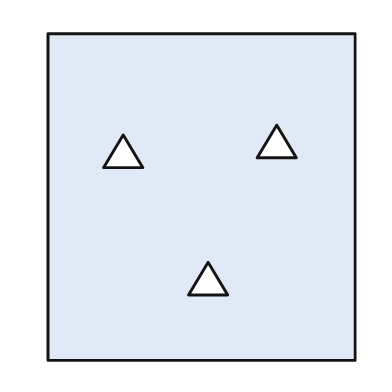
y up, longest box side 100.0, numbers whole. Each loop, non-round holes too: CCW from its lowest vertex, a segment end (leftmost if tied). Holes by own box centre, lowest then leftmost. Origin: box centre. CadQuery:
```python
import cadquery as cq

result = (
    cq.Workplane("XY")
    .moveTo(-47.0, -50.0)
    .lineTo(47.0, -50.0)
    .lineTo(47.0, 50.0)
    .lineTo(-47.0, 50.0)
    .close()
    .moveTo(-4.0, -30.0)
    .lineTo(8.0, -30.0)
    .lineTo(2.0, -20.0)
    .close()
    .moveTo(-30.0, 9.0)
    .lineTo(-18.0, 9.0)
    .lineTo(-24.0, 19.0)
    .close()
    .moveTo(17.0, 12.0)
    .lineTo(29.0, 12.0)
    .lineTo(23.0, 22.0)
    .close()
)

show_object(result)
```